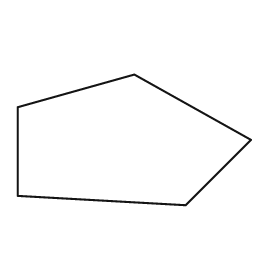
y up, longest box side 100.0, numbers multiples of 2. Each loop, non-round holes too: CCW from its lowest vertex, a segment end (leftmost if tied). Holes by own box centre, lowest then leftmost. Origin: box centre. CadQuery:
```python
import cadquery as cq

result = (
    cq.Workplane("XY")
    .moveTo(22.0, -28.0)
    .lineTo(50.0, 0.0)
    .lineTo(0.0, 28.0)
    .lineTo(-50.0, 14.0)
    .lineTo(-50.0, -24.0)
    .close()
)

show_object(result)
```